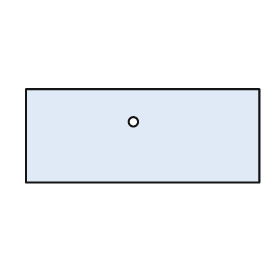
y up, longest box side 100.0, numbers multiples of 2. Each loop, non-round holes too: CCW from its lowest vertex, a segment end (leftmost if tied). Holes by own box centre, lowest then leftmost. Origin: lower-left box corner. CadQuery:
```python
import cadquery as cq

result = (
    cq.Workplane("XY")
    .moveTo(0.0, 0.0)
    .lineTo(100.0, 0.0)
    .lineTo(100.0, 40.0)
    .lineTo(0.0, 40.0)
    .close()
    .moveTo(46.0, 26.0)
    .circle(2.0)
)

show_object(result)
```